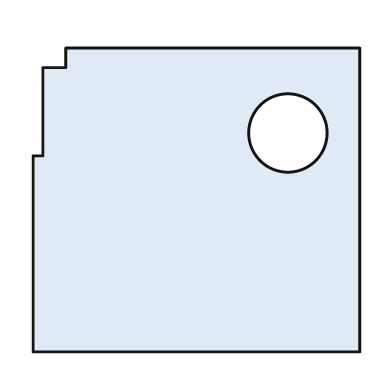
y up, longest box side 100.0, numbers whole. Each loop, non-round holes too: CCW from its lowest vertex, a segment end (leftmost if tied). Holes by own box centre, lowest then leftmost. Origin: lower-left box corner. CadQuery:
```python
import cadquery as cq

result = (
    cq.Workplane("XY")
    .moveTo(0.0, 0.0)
    .lineTo(100.0, 0.0)
    .lineTo(100.0, 93.0)
    .lineTo(10.0, 93.0)
    .lineTo(10.0, 87.0)
    .lineTo(3.0, 87.0)
    .lineTo(3.0, 60.0)
    .lineTo(0.0, 60.0)
    .close()
    .moveTo(78.0, 67.0)
    .circle(12.0)
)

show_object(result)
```